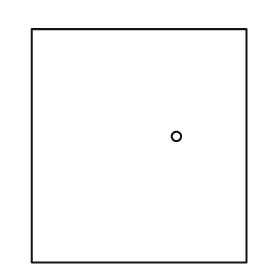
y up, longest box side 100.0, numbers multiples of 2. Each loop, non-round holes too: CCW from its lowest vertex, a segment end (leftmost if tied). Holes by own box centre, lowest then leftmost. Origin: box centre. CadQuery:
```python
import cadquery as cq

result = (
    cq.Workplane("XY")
    .moveTo(-46.0, -50.0)
    .lineTo(46.0, -50.0)
    .lineTo(46.0, 50.0)
    .lineTo(-46.0, 50.0)
    .close()
    .moveTo(16.0, 4.0)
    .circle(2.0)
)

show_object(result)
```